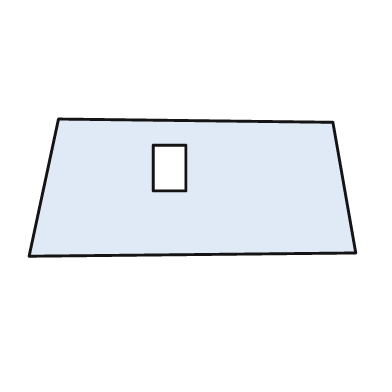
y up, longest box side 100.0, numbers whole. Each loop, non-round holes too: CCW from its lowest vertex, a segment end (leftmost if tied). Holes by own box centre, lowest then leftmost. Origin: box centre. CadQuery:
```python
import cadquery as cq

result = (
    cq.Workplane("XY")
    .moveTo(-50.0, -21.0)
    .lineTo(50.0, -20.0)
    .lineTo(43.0, 20.0)
    .lineTo(-41.0, 21.0)
    .close()
    .moveTo(-12.0, -1.0)
    .lineTo(-2.0, -1.0)
    .lineTo(-2.0, 13.0)
    .lineTo(-12.0, 13.0)
    .close()
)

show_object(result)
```